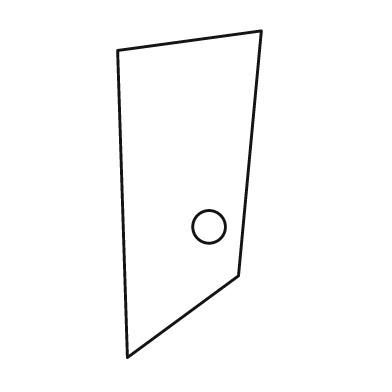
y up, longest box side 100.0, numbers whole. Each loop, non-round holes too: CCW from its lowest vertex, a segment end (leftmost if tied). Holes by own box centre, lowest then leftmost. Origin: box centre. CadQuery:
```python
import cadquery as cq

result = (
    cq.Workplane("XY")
    .moveTo(-19.0, -50.0)
    .lineTo(15.0, -25.0)
    .lineTo(22.0, 50.0)
    .lineTo(-22.0, 44.0)
    .close()
    .moveTo(6.0, -10.0)
    .circle(5.0)
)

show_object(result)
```